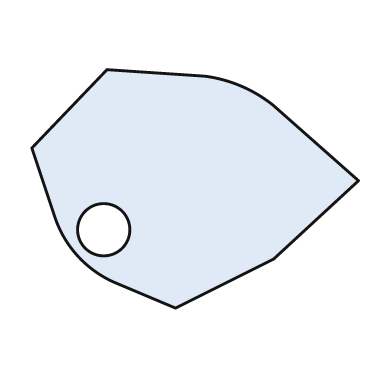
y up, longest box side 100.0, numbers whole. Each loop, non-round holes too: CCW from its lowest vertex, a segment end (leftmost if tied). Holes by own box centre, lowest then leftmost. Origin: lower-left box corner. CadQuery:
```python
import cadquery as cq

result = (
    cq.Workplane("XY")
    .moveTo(44.0, 0.0)
    .lineTo(74.0, 15.0)
    .lineTo(100.0, 39.0)
    .lineTo(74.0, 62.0)
    .threePointArc((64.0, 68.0), (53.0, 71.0))
    .lineTo(23.0, 73.0)
    .lineTo(0.0, 49.0)
    .lineTo(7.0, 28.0)
    .threePointArc((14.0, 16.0), (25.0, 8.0))
    .close()
    .moveTo(22.0, 24.0)
    .circle(8.0)
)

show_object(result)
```